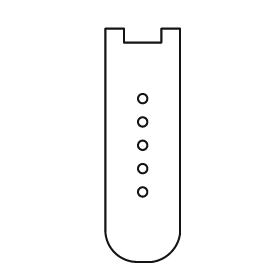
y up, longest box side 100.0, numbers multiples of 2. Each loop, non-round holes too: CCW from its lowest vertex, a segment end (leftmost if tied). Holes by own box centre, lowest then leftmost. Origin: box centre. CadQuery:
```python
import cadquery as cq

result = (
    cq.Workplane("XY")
    .moveTo(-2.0, -50.0)
    .lineTo(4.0, -50.0)
    .threePointArc((12.0, -46.0), (16.0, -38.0))
    .lineTo(16.0, 50.0)
    .lineTo(8.0, 50.0)
    .lineTo(8.0, 44.0)
    .lineTo(-8.0, 44.0)
    .lineTo(-8.0, 50.0)
    .lineTo(-16.0, 50.0)
    .lineTo(-16.0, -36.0)
    .threePointArc((-12.0, -46.0), (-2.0, -50.0))
    .close()
    .moveTo(0.0, -20.0)
    .circle(2.0)
    .moveTo(0.0, -10.0)
    .circle(2.0)
    .moveTo(0.0, 0.0)
    .circle(2.0)
    .moveTo(0.0, 10.0)
    .circle(2.0)
    .moveTo(0.0, 20.0)
    .circle(2.0)
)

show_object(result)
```